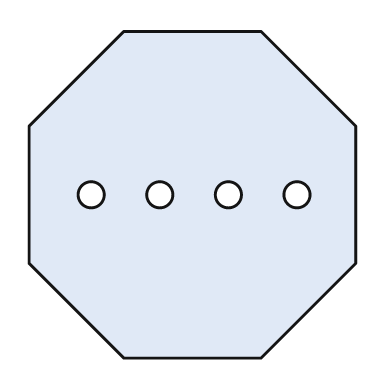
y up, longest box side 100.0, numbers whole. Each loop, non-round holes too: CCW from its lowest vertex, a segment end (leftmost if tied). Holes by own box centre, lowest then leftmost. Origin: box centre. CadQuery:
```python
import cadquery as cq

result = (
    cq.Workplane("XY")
    .moveTo(-21.0, -50.0)
    .lineTo(21.0, -50.0)
    .lineTo(50.0, -21.0)
    .lineTo(50.0, 21.0)
    .lineTo(21.0, 50.0)
    .lineTo(-21.0, 50.0)
    .lineTo(-50.0, 21.0)
    .lineTo(-50.0, -21.0)
    .close()
    .moveTo(-31.0, 0.0)
    .circle(4.0)
    .moveTo(-10.0, 0.0)
    .circle(4.0)
    .moveTo(11.0, 0.0)
    .circle(4.0)
    .moveTo(32.0, 0.0)
    .circle(4.0)
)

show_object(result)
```